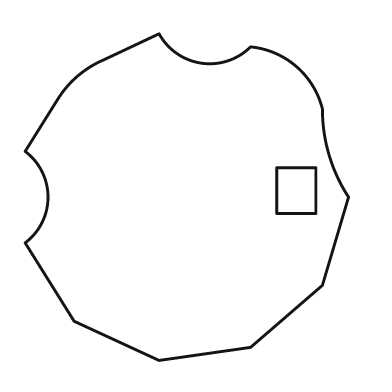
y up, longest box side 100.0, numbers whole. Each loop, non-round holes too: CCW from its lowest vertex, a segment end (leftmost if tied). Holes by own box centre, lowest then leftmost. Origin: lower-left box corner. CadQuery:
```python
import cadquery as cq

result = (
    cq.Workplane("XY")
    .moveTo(41.0, 0.0)
    .lineTo(69.0, 4.0)
    .lineTo(91.0, 23.0)
    .lineTo(99.0, 50.0)
    .threePointArc((93.0, 63.0), (91.0, 77.0))
    .threePointArc((83.0, 90.0), (69.0, 96.0))
    .threePointArc((54.0, 91.0), (41.0, 100.0))
    .lineTo(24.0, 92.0)
    .threePointArc((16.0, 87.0), (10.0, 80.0))
    .lineTo(0.0, 64.0)
    .threePointArc((7.0, 50.0), (0.0, 36.0))
    .lineTo(15.0, 12.0)
    .close()
    .moveTo(77.0, 45.0)
    .lineTo(89.0, 45.0)
    .lineTo(89.0, 59.0)
    .lineTo(77.0, 59.0)
    .close()
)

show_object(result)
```